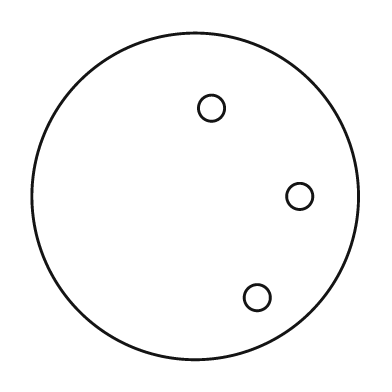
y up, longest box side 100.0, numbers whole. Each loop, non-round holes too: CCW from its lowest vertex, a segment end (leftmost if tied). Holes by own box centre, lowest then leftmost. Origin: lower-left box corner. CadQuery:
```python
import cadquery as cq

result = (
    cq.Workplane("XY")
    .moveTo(50.0, 50.0)
    .circle(50.0)
    .moveTo(69.0, 19.0)
    .circle(4.0)
    .moveTo(82.0, 50.0)
    .circle(4.0)
    .moveTo(55.0, 77.0)
    .circle(4.0)
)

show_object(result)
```